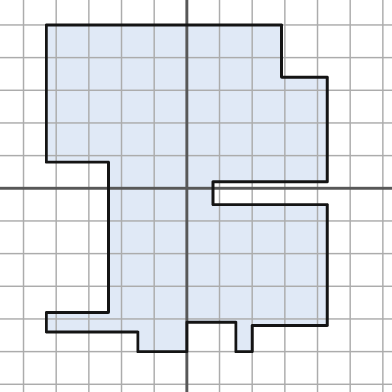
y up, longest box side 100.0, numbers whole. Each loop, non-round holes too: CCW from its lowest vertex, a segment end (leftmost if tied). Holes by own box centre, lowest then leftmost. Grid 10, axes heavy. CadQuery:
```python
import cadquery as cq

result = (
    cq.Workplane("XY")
    .moveTo(-15.0, -50.0)
    .lineTo(0.0, -50.0)
    .lineTo(0.0, -41.0)
    .lineTo(15.0, -41.0)
    .lineTo(15.0, -50.0)
    .lineTo(20.0, -50.0)
    .lineTo(20.0, -42.0)
    .lineTo(43.0, -42.0)
    .lineTo(43.0, -5.0)
    .lineTo(8.0, -5.0)
    .lineTo(8.0, 2.0)
    .lineTo(43.0, 2.0)
    .lineTo(43.0, 34.0)
    .lineTo(29.0, 34.0)
    .lineTo(29.0, 50.0)
    .lineTo(-43.0, 50.0)
    .lineTo(-43.0, 8.0)
    .lineTo(-24.0, 8.0)
    .lineTo(-24.0, -38.0)
    .lineTo(-43.0, -38.0)
    .lineTo(-43.0, -44.0)
    .lineTo(-15.0, -44.0)
    .close()
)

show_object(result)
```